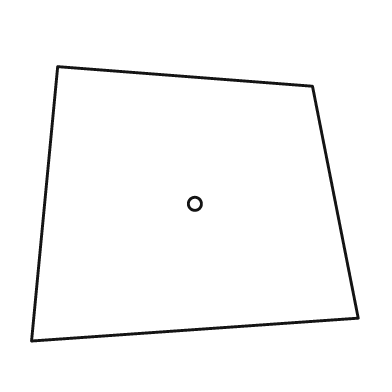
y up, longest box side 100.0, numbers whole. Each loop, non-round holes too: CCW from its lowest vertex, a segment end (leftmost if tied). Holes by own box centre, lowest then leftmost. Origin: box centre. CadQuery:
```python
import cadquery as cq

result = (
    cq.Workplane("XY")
    .moveTo(-50.0, -42.0)
    .lineTo(50.0, -35.0)
    .lineTo(36.0, 36.0)
    .lineTo(-42.0, 42.0)
    .close()
    .moveTo(0.0, 0.0)
    .circle(2.0)
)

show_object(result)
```